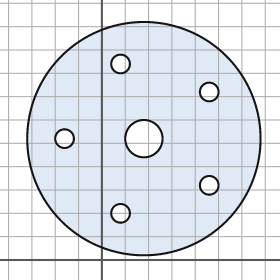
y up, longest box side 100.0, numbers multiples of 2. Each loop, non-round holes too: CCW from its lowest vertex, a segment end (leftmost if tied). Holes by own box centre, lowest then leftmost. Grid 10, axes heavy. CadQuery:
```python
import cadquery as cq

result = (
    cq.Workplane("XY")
    .moveTo(18.0, 52.0)
    .circle(50.0)
    .moveTo(8.0, 20.0)
    .circle(4.0)
    .moveTo(46.0, 32.0)
    .circle(4.0)
    .moveTo(-16.0, 52.0)
    .circle(4.0)
    .moveTo(18.0, 52.0)
    .circle(8.0)
    .moveTo(46.0, 72.0)
    .circle(4.0)
    .moveTo(8.0, 84.0)
    .circle(4.0)
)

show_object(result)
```